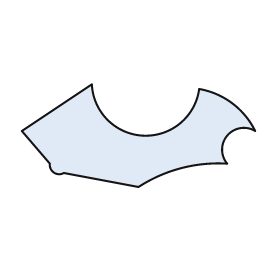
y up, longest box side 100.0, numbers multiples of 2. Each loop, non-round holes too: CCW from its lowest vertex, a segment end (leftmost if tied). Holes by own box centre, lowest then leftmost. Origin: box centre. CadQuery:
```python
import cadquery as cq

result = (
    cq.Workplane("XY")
    .moveTo(0.0, -22.0)
    .threePointArc((18.0, -14.0), (38.0, -12.0))
    .threePointArc((38.0, 0.0), (50.0, 2.0))
    .threePointArc((40.0, 14.0), (26.0, 20.0))
    .threePointArc((2.0, 0.0), (-20.0, 22.0))
    .lineTo(-50.0, 2.0)
    .lineTo(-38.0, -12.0)
    .threePointArc((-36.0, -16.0), (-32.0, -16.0))
    .close()
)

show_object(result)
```